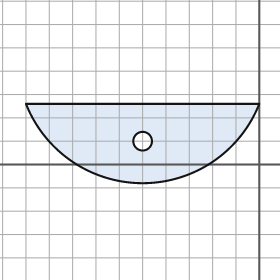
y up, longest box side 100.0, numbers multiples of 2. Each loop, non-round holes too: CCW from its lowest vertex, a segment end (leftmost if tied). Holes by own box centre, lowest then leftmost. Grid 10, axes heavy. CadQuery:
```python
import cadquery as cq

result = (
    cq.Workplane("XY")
    .moveTo(-100.0, 26.0)
    .threePointArc((-50.0, -8.0), (0.0, 26.0))
    .close()
    .moveTo(-50.0, 10.0)
    .circle(4.0)
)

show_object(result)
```